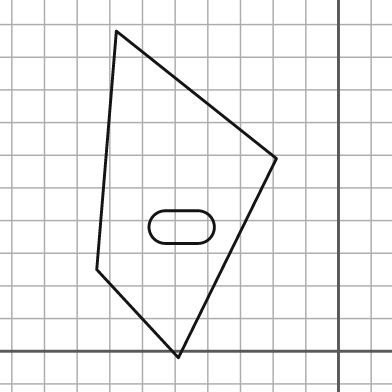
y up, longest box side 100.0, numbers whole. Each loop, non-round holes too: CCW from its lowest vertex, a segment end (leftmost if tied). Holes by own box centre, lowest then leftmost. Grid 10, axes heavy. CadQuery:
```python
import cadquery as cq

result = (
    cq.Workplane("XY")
    .moveTo(-49.0, -2.0)
    .lineTo(-19.0, 59.0)
    .lineTo(-68.0, 98.0)
    .lineTo(-74.0, 25.0)
    .close()
    .moveTo(-53.0, 33.0)
    .lineTo(-43.0, 33.0)
    .threePointArc((-38.0, 38.0), (-43.0, 43.0))
    .lineTo(-53.0, 43.0)
    .threePointArc((-58.0, 38.0), (-53.0, 33.0))
    .close()
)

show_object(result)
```